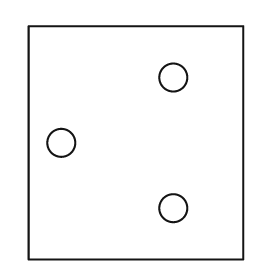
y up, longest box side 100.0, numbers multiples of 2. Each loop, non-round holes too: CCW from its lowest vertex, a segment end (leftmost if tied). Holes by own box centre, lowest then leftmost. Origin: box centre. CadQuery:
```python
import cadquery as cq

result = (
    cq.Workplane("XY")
    .moveTo(-46.0, -50.0)
    .lineTo(46.0, -50.0)
    .lineTo(46.0, 50.0)
    .lineTo(-46.0, 50.0)
    .close()
    .moveTo(16.0, -28.0)
    .circle(6.0)
    .moveTo(-32.0, 0.0)
    .circle(6.0)
    .moveTo(16.0, 28.0)
    .circle(6.0)
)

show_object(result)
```